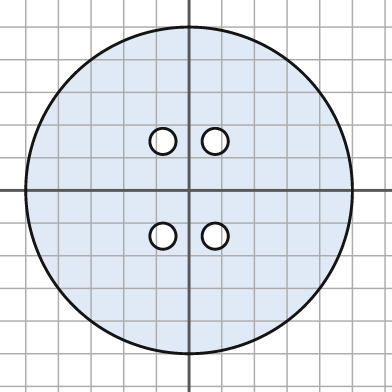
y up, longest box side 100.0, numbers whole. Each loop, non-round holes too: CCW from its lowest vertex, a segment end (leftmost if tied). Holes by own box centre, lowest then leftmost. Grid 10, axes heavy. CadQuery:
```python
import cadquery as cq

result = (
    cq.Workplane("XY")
    .moveTo(0.0, 0.0)
    .circle(50.0)
    .moveTo(-8.0, -14.0)
    .circle(4.0)
    .moveTo(8.0, -14.0)
    .circle(4.0)
    .moveTo(-8.0, 15.0)
    .circle(4.0)
    .moveTo(8.0, 15.0)
    .circle(4.0)
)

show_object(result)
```